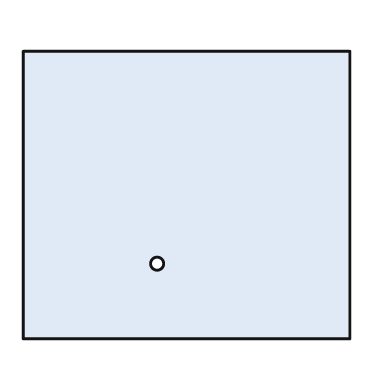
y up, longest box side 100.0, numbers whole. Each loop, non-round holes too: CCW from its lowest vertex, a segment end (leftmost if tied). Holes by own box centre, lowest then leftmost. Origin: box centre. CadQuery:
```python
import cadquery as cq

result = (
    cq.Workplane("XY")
    .moveTo(-50.0, -44.0)
    .lineTo(50.0, -44.0)
    .lineTo(50.0, 44.0)
    .lineTo(-50.0, 44.0)
    .close()
    .moveTo(-9.0, -21.0)
    .circle(2.0)
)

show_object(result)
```